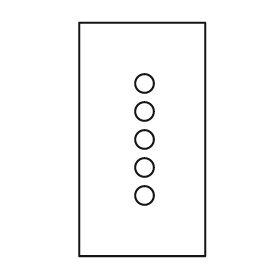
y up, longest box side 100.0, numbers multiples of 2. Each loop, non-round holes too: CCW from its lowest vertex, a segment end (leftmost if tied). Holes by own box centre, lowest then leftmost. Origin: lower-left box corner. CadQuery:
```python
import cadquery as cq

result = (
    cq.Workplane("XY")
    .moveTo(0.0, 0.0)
    .lineTo(54.0, 0.0)
    .lineTo(54.0, 100.0)
    .lineTo(0.0, 100.0)
    .close()
    .moveTo(28.0, 26.0)
    .circle(4.0)
    .moveTo(28.0, 38.0)
    .circle(4.0)
    .moveTo(28.0, 50.0)
    .circle(4.0)
    .moveTo(28.0, 62.0)
    .circle(4.0)
    .moveTo(28.0, 74.0)
    .circle(4.0)
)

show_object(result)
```